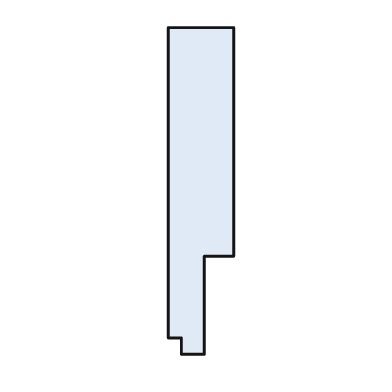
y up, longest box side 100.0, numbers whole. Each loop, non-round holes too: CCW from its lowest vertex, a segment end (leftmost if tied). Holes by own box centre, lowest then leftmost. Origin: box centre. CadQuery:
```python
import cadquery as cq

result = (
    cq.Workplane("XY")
    .moveTo(-6.0, -50.0)
    .lineTo(1.0, -50.0)
    .lineTo(1.0, -20.0)
    .lineTo(10.0, -20.0)
    .lineTo(10.0, 50.0)
    .lineTo(-10.0, 50.0)
    .lineTo(-10.0, -45.0)
    .lineTo(-6.0, -45.0)
    .close()
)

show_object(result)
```